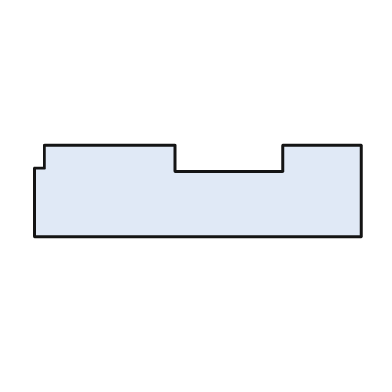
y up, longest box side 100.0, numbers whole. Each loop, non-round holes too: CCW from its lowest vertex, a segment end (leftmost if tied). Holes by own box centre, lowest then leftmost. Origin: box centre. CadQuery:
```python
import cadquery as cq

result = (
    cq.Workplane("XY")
    .moveTo(-50.0, -14.0)
    .lineTo(50.0, -14.0)
    .lineTo(50.0, 14.0)
    .lineTo(26.0, 14.0)
    .lineTo(26.0, 6.0)
    .lineTo(-7.0, 6.0)
    .lineTo(-7.0, 14.0)
    .lineTo(-47.0, 14.0)
    .lineTo(-47.0, 7.0)
    .lineTo(-50.0, 7.0)
    .close()
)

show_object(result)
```